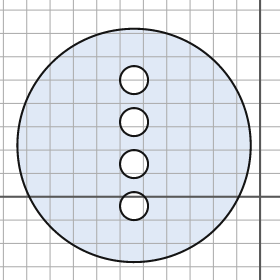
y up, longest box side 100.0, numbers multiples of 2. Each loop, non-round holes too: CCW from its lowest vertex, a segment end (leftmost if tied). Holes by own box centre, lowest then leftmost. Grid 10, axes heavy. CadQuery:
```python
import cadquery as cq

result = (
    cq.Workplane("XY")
    .moveTo(-54.0, 22.0)
    .circle(50.0)
    .moveTo(-54.0, -4.0)
    .circle(6.0)
    .moveTo(-54.0, 14.0)
    .circle(6.0)
    .moveTo(-54.0, 32.0)
    .circle(6.0)
    .moveTo(-54.0, 50.0)
    .circle(6.0)
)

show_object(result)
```